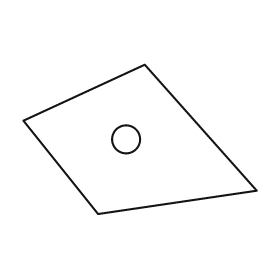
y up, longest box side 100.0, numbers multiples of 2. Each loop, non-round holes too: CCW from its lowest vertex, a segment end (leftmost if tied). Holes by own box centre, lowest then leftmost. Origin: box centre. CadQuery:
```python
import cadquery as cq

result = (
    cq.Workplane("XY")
    .moveTo(-18.0, -32.0)
    .lineTo(50.0, -22.0)
    .lineTo(2.0, 32.0)
    .lineTo(-50.0, 8.0)
    .close()
    .moveTo(-6.0, 0.0)
    .circle(6.0)
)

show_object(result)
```